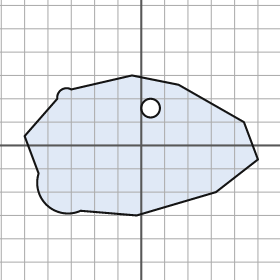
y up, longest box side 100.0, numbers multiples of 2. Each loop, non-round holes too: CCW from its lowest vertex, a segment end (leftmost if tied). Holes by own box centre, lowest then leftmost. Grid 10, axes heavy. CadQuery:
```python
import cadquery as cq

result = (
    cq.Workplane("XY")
    .moveTo(-2.0, -30.0)
    .lineTo(32.0, -20.0)
    .lineTo(50.0, -6.0)
    .lineTo(44.0, 10.0)
    .lineTo(16.0, 26.0)
    .lineTo(-4.0, 30.0)
    .lineTo(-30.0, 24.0)
    .threePointArc((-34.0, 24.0), (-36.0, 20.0))
    .lineTo(-50.0, 4.0)
    .lineTo(-44.0, -12.0)
    .threePointArc((-40.0, -26.0), (-26.0, -28.0))
    .close()
    .moveTo(4.0, 16.0)
    .circle(4.0)
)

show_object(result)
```